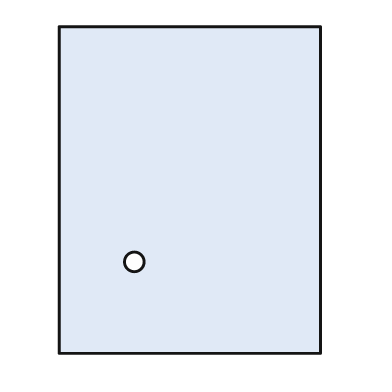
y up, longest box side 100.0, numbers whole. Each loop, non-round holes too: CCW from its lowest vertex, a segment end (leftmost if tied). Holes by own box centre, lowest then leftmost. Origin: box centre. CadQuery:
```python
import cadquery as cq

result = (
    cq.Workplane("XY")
    .moveTo(-40.0, -50.0)
    .lineTo(40.0, -50.0)
    .lineTo(40.0, 50.0)
    .lineTo(-40.0, 50.0)
    .close()
    .moveTo(-17.0, -22.0)
    .circle(3.0)
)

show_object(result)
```